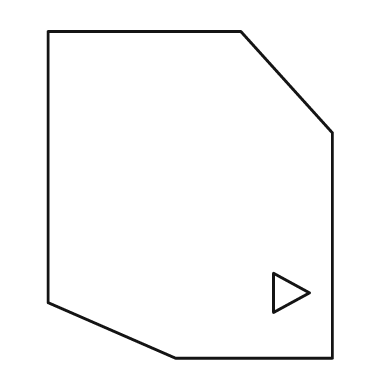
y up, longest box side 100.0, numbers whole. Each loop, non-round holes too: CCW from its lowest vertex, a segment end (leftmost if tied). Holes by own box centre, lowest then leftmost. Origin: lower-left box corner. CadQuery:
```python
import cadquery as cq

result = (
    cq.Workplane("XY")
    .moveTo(39.0, 0.0)
    .lineTo(87.0, 0.0)
    .lineTo(87.0, 69.0)
    .lineTo(59.0, 100.0)
    .lineTo(0.0, 100.0)
    .lineTo(0.0, 17.0)
    .close()
    .moveTo(69.0, 14.0)
    .lineTo(80.0, 20.0)
    .lineTo(69.0, 26.0)
    .close()
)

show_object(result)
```